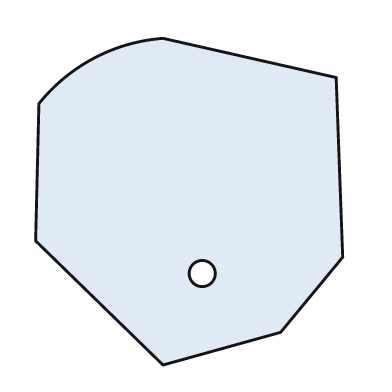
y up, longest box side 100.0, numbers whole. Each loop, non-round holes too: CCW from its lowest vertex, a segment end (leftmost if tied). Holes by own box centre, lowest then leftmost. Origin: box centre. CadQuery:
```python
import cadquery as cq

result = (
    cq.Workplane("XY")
    .moveTo(-8.0, -50.0)
    .lineTo(28.0, -40.0)
    .lineTo(47.0, -17.0)
    .lineTo(45.0, 38.0)
    .lineTo(-8.0, 50.0)
    .threePointArc((-29.0, 44.0), (-46.0, 30.0))
    .lineTo(-47.0, -12.0)
    .close()
    .moveTo(4.0, -22.0)
    .circle(4.0)
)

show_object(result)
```